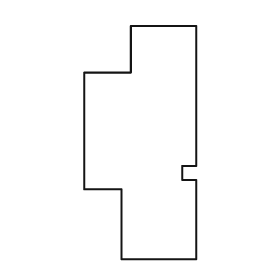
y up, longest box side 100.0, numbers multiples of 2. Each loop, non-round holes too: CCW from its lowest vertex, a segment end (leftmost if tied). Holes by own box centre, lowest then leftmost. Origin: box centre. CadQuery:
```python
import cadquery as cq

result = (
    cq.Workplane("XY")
    .moveTo(-8.0, -50.0)
    .lineTo(24.0, -50.0)
    .lineTo(24.0, -16.0)
    .lineTo(18.0, -16.0)
    .lineTo(18.0, -10.0)
    .lineTo(24.0, -10.0)
    .lineTo(24.0, 50.0)
    .lineTo(-4.0, 50.0)
    .lineTo(-4.0, 30.0)
    .lineTo(-24.0, 30.0)
    .lineTo(-24.0, -20.0)
    .lineTo(-8.0, -20.0)
    .close()
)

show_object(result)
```